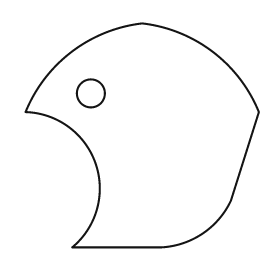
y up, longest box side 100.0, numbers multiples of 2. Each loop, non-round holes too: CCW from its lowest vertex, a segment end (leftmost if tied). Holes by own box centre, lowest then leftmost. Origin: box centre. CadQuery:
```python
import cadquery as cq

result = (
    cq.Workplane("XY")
    .moveTo(-30.0, -48.0)
    .lineTo(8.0, -48.0)
    .threePointArc((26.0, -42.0), (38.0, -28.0))
    .lineTo(50.0, 10.0)
    .threePointArc((30.0, 36.0), (0.0, 48.0))
    .threePointArc((-30.0, 36.0), (-50.0, 10.0))
    .threePointArc((-20.0, -12.0), (-30.0, -48.0))
    .close()
    .moveTo(-22.0, 18.0)
    .circle(6.0)
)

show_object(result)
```